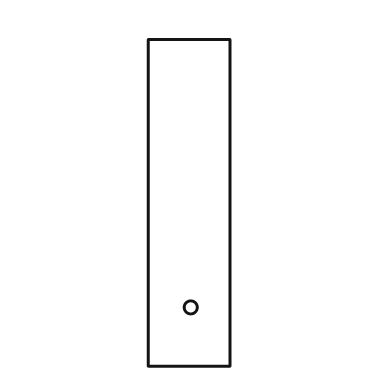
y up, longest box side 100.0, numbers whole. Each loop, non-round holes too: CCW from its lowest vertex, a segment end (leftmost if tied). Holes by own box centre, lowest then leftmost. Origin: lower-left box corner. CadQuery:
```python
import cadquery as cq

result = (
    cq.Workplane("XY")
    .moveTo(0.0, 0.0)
    .lineTo(25.0, 0.0)
    .lineTo(25.0, 100.0)
    .lineTo(0.0, 100.0)
    .close()
    .moveTo(13.0, 18.0)
    .circle(2.0)
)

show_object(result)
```